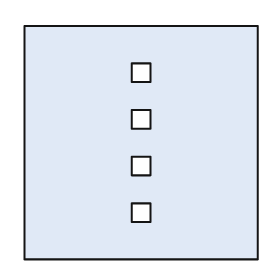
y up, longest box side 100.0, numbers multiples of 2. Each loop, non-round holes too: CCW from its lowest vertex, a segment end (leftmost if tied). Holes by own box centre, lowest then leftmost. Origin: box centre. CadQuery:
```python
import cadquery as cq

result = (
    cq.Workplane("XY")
    .moveTo(-50.0, -50.0)
    .lineTo(50.0, -50.0)
    .lineTo(50.0, 50.0)
    .lineTo(-50.0, 50.0)
    .close()
    .moveTo(-4.0, -34.0)
    .lineTo(4.0, -34.0)
    .lineTo(4.0, -26.0)
    .lineTo(-4.0, -26.0)
    .close()
    .moveTo(-4.0, -14.0)
    .lineTo(4.0, -14.0)
    .lineTo(4.0, -6.0)
    .lineTo(-4.0, -6.0)
    .close()
    .moveTo(-4.0, 6.0)
    .lineTo(4.0, 6.0)
    .lineTo(4.0, 14.0)
    .lineTo(-4.0, 14.0)
    .close()
    .moveTo(-4.0, 26.0)
    .lineTo(4.0, 26.0)
    .lineTo(4.0, 34.0)
    .lineTo(-4.0, 34.0)
    .close()
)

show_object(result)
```